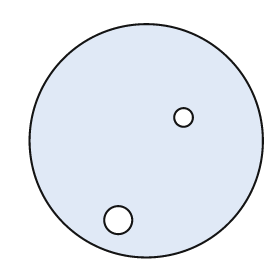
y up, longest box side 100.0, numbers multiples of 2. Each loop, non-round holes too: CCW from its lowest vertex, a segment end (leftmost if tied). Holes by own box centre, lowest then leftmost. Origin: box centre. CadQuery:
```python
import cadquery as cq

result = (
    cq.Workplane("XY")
    .moveTo(0.0, 0.0)
    .circle(50.0)
    .moveTo(-12.0, -34.0)
    .circle(6.0)
    .moveTo(16.0, 10.0)
    .circle(4.0)
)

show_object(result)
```